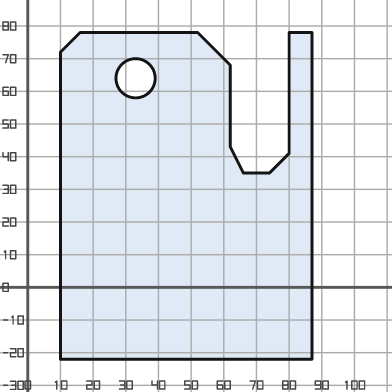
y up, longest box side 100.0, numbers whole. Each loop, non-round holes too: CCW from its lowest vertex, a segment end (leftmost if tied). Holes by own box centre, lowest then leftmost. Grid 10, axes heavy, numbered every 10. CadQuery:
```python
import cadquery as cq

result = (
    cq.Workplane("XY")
    .moveTo(10.0, -22.0)
    .lineTo(87.0, -22.0)
    .lineTo(87.0, 78.0)
    .lineTo(80.0, 78.0)
    .lineTo(80.0, 41.0)
    .lineTo(74.0, 35.0)
    .lineTo(66.0, 35.0)
    .lineTo(62.0, 43.0)
    .lineTo(62.0, 68.0)
    .lineTo(52.0, 78.0)
    .lineTo(16.0, 78.0)
    .lineTo(10.0, 72.0)
    .close()
    .moveTo(33.0, 64.0)
    .circle(6.0)
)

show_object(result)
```